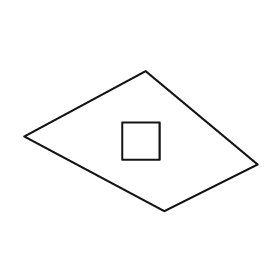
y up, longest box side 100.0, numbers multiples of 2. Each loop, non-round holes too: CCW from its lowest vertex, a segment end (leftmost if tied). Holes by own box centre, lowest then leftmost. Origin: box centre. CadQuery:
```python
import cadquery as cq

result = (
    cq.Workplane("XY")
    .moveTo(10.0, -30.0)
    .lineTo(50.0, -10.0)
    .lineTo(2.0, 30.0)
    .lineTo(-50.0, 2.0)
    .close()
    .moveTo(-8.0, -8.0)
    .lineTo(8.0, -8.0)
    .lineTo(8.0, 8.0)
    .lineTo(-8.0, 8.0)
    .close()
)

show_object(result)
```